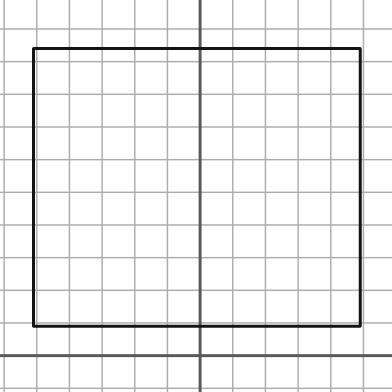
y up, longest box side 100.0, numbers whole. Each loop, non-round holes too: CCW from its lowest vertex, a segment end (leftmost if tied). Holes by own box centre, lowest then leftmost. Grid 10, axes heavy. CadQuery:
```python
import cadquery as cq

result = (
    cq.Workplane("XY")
    .moveTo(-51.0, 9.0)
    .lineTo(49.0, 9.0)
    .lineTo(49.0, 94.0)
    .lineTo(-51.0, 94.0)
    .close()
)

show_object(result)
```